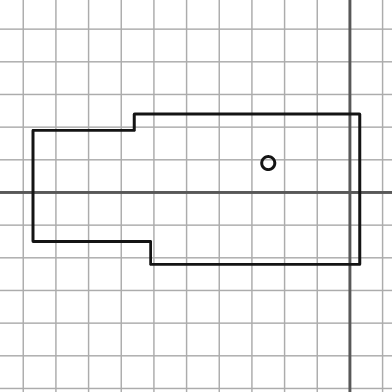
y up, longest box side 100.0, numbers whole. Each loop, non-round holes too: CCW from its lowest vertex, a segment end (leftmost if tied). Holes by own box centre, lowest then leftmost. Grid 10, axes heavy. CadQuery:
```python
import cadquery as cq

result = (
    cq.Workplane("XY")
    .moveTo(-61.0, -22.0)
    .lineTo(3.0, -22.0)
    .lineTo(3.0, 24.0)
    .lineTo(-66.0, 24.0)
    .lineTo(-66.0, 19.0)
    .lineTo(-97.0, 19.0)
    .lineTo(-97.0, -15.0)
    .lineTo(-61.0, -15.0)
    .close()
    .moveTo(-25.0, 9.0)
    .circle(2.0)
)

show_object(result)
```